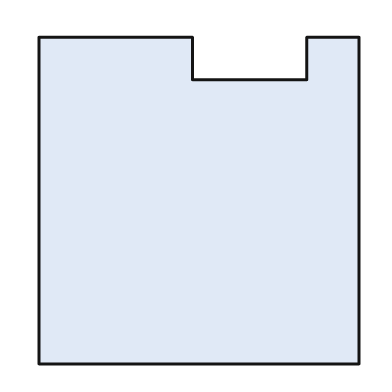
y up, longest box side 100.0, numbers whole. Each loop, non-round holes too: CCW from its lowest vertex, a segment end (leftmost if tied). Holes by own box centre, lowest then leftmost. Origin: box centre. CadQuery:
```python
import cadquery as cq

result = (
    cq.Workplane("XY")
    .moveTo(-49.0, -50.0)
    .lineTo(49.0, -50.0)
    .lineTo(49.0, 50.0)
    .lineTo(33.0, 50.0)
    .lineTo(33.0, 37.0)
    .lineTo(-2.0, 37.0)
    .lineTo(-2.0, 50.0)
    .lineTo(-49.0, 50.0)
    .close()
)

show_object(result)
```